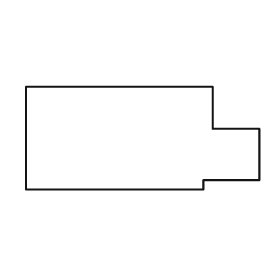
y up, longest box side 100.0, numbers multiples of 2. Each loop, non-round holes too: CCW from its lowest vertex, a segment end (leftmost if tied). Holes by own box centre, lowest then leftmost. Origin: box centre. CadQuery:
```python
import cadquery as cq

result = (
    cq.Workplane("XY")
    .moveTo(-50.0, -22.0)
    .lineTo(26.0, -22.0)
    .lineTo(26.0, -18.0)
    .lineTo(50.0, -18.0)
    .lineTo(50.0, 4.0)
    .lineTo(30.0, 4.0)
    .lineTo(30.0, 22.0)
    .lineTo(-50.0, 22.0)
    .close()
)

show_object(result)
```